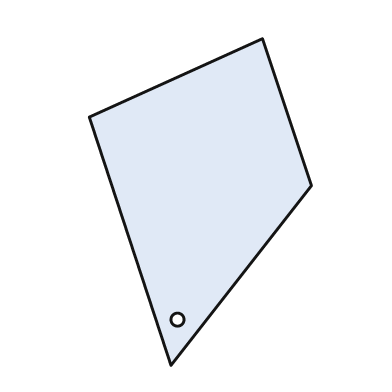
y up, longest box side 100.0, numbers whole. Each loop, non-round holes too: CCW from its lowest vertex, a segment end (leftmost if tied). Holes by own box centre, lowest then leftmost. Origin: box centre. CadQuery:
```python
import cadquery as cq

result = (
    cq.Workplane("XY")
    .moveTo(-9.0, -50.0)
    .lineTo(34.0, 5.0)
    .lineTo(19.0, 50.0)
    .lineTo(-34.0, 26.0)
    .close()
    .moveTo(-7.0, -36.0)
    .circle(2.0)
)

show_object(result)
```